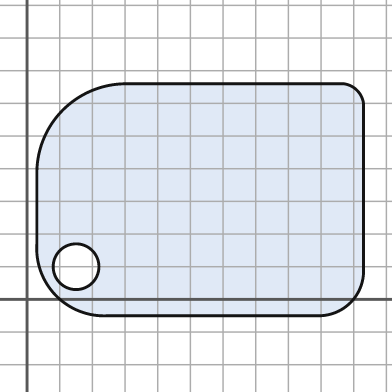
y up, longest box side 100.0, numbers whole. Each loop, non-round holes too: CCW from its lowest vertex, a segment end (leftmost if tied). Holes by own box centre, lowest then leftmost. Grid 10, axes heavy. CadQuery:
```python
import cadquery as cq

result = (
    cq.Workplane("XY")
    .moveTo(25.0, -5.0)
    .lineTo(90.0, -5.0)
    .threePointArc((99.0, -1.0), (103.0, 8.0))
    .lineTo(103.0, 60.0)
    .threePointArc((101.0, 64.0), (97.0, 66.0))
    .lineTo(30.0, 66.0)
    .threePointArc((11.0, 58.0), (3.0, 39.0))
    .lineTo(3.0, 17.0)
    .threePointArc((9.0, 1.0), (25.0, -5.0))
    .close()
    .moveTo(15.0, 10.0)
    .circle(7.0)
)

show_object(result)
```